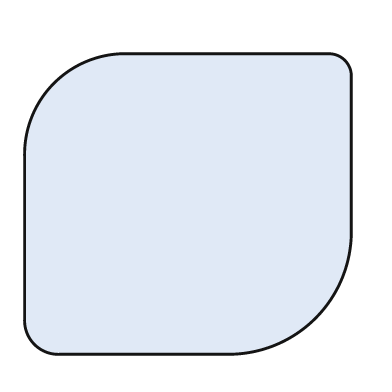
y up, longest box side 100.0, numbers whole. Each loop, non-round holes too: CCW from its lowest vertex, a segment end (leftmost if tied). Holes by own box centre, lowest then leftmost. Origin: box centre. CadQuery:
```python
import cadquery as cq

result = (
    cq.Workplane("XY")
    .moveTo(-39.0, -46.0)
    .lineTo(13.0, -46.0)
    .threePointArc((39.0, -35.0), (50.0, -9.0))
    .lineTo(50.0, 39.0)
    .threePointArc((48.0, 44.0), (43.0, 46.0))
    .lineTo(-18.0, 46.0)
    .threePointArc((-41.0, 37.0), (-50.0, 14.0))
    .lineTo(-50.0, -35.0)
    .threePointArc((-47.0, -43.0), (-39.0, -46.0))
    .close()
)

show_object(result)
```